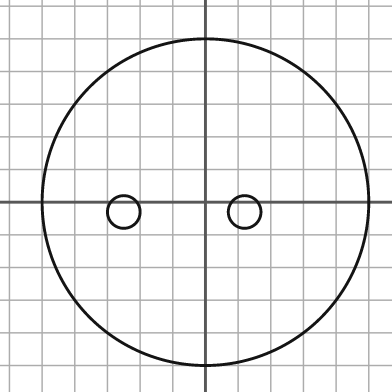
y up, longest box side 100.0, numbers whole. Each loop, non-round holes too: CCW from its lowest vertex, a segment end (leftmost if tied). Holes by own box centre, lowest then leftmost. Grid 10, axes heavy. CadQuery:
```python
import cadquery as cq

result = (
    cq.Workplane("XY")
    .moveTo(0.0, 0.0)
    .circle(50.0)
    .moveTo(-25.0, -3.0)
    .circle(5.0)
    .moveTo(12.0, -3.0)
    .circle(5.0)
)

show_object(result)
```